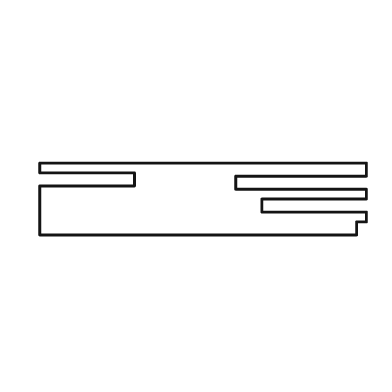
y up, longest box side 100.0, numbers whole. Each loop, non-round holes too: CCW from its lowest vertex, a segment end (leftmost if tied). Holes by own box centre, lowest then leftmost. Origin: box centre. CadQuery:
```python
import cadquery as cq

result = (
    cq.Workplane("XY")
    .moveTo(-50.0, -11.0)
    .lineTo(47.0, -11.0)
    .lineTo(47.0, -7.0)
    .lineTo(50.0, -7.0)
    .lineTo(50.0, -4.0)
    .lineTo(18.0, -4.0)
    .lineTo(18.0, 0.0)
    .lineTo(50.0, 0.0)
    .lineTo(50.0, 3.0)
    .lineTo(10.0, 3.0)
    .lineTo(10.0, 7.0)
    .lineTo(50.0, 7.0)
    .lineTo(50.0, 11.0)
    .lineTo(-50.0, 11.0)
    .lineTo(-50.0, 8.0)
    .lineTo(-21.0, 8.0)
    .lineTo(-21.0, 4.0)
    .lineTo(-50.0, 4.0)
    .close()
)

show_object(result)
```